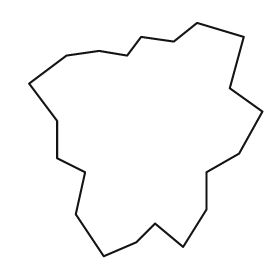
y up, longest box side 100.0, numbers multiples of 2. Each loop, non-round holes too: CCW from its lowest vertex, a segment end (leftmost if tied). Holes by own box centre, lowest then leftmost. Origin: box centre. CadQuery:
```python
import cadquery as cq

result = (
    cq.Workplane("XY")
    .moveTo(-18.0, -50.0)
    .lineTo(-4.0, -44.0)
    .lineTo(4.0, -36.0)
    .lineTo(16.0, -46.0)
    .lineTo(26.0, -30.0)
    .lineTo(26.0, -14.0)
    .lineTo(40.0, -6.0)
    .lineTo(50.0, 12.0)
    .lineTo(36.0, 22.0)
    .lineTo(42.0, 44.0)
    .lineTo(22.0, 50.0)
    .lineTo(12.0, 42.0)
    .lineTo(-2.0, 44.0)
    .lineTo(-8.0, 36.0)
    .lineTo(-20.0, 38.0)
    .lineTo(-34.0, 36.0)
    .lineTo(-50.0, 24.0)
    .lineTo(-38.0, 8.0)
    .lineTo(-38.0, -8.0)
    .lineTo(-26.0, -14.0)
    .lineTo(-30.0, -32.0)
    .close()
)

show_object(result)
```